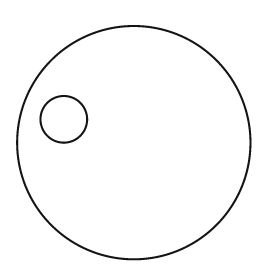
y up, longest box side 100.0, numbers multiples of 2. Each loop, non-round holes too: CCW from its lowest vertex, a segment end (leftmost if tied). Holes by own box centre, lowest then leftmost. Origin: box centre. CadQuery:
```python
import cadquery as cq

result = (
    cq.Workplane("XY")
    .moveTo(0.0, 0.0)
    .circle(50.0)
    .moveTo(-30.0, 10.0)
    .circle(10.0)
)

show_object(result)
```